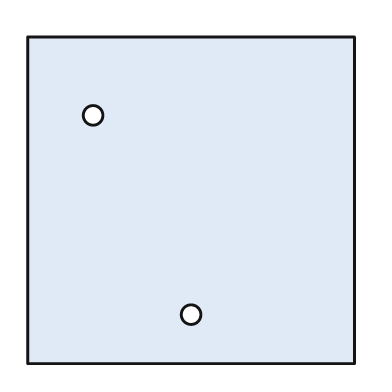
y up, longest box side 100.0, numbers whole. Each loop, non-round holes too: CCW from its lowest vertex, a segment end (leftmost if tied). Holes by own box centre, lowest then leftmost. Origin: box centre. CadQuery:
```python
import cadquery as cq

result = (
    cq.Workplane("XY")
    .moveTo(-50.0, -50.0)
    .lineTo(50.0, -50.0)
    .lineTo(50.0, 50.0)
    .lineTo(-50.0, 50.0)
    .close()
    .moveTo(0.0, -35.0)
    .circle(3.0)
    .moveTo(-30.0, 26.0)
    .circle(3.0)
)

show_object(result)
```